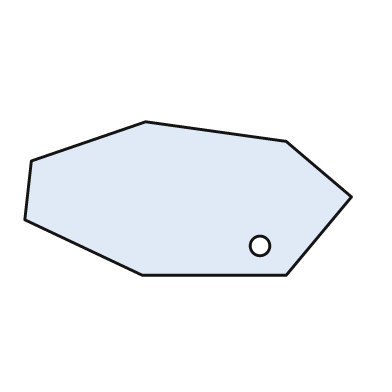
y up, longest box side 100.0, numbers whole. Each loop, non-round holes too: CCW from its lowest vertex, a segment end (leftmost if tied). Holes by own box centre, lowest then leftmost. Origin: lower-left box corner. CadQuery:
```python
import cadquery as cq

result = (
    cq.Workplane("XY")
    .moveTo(36.0, 0.0)
    .lineTo(80.0, 0.0)
    .lineTo(100.0, 24.0)
    .lineTo(80.0, 41.0)
    .lineTo(37.0, 47.0)
    .lineTo(2.0, 35.0)
    .lineTo(0.0, 17.0)
    .close()
    .moveTo(72.0, 9.0)
    .circle(3.0)
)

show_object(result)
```